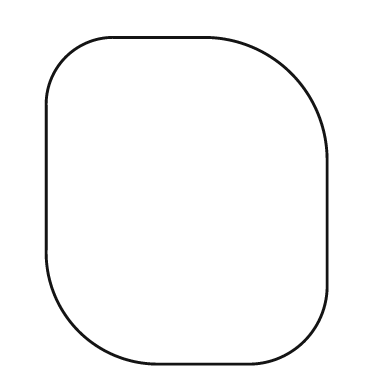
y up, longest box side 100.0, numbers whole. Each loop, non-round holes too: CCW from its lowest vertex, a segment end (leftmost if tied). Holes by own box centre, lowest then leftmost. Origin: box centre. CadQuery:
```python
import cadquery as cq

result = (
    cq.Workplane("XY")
    .moveTo(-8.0, -50.0)
    .lineTo(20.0, -50.0)
    .threePointArc((36.0, -43.0), (43.0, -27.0))
    .lineTo(43.0, 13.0)
    .threePointArc((32.0, 39.0), (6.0, 50.0))
    .lineTo(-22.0, 50.0)
    .threePointArc((-37.0, 44.0), (-43.0, 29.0))
    .lineTo(-43.0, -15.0)
    .threePointArc((-33.0, -40.0), (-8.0, -50.0))
    .close()
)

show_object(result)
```